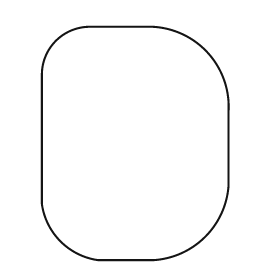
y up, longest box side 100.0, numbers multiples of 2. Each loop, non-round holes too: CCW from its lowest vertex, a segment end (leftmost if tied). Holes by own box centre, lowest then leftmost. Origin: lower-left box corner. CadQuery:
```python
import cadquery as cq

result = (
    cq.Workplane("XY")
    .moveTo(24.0, 0.0)
    .lineTo(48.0, 0.0)
    .threePointArc((70.0, 10.0), (80.0, 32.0))
    .lineTo(80.0, 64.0)
    .threePointArc((70.0, 90.0), (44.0, 100.0))
    .lineTo(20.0, 100.0)
    .threePointArc((6.0, 94.0), (0.0, 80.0))
    .lineTo(0.0, 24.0)
    .threePointArc((8.0, 8.0), (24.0, 0.0))
    .close()
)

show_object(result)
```